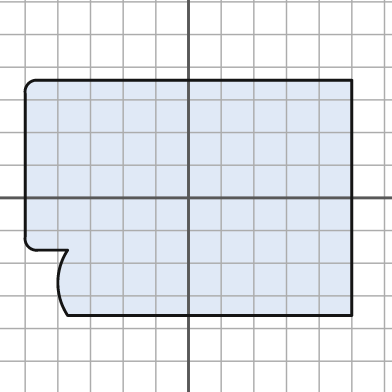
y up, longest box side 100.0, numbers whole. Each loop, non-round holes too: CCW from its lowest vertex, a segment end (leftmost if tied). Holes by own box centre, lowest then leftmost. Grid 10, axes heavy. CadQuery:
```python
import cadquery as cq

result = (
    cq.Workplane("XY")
    .moveTo(-37.0, -36.0)
    .lineTo(50.0, -36.0)
    .lineTo(50.0, 36.0)
    .lineTo(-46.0, 36.0)
    .threePointArc((-49.0, 35.0), (-50.0, 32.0))
    .lineTo(-50.0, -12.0)
    .threePointArc((-49.0, -15.0), (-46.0, -16.0))
    .lineTo(-37.0, -16.0)
    .threePointArc((-40.0, -26.0), (-37.0, -36.0))
    .close()
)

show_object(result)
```